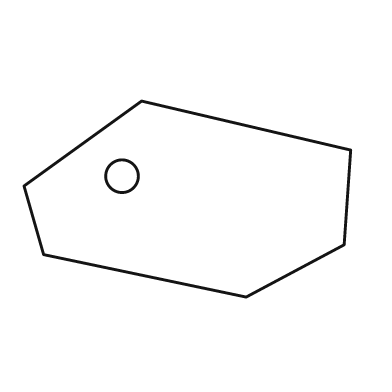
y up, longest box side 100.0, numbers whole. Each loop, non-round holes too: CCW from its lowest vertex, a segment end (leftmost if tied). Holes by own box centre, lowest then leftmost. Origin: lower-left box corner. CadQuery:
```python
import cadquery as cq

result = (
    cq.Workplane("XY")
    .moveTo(68.0, 0.0)
    .lineTo(98.0, 16.0)
    .lineTo(100.0, 45.0)
    .lineTo(36.0, 60.0)
    .lineTo(0.0, 34.0)
    .lineTo(6.0, 13.0)
    .close()
    .moveTo(30.0, 37.0)
    .circle(5.0)
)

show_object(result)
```